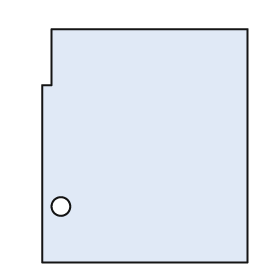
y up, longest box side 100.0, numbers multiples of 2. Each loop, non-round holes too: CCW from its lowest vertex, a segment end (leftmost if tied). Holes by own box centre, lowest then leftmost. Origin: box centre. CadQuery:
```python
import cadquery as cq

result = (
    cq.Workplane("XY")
    .moveTo(-44.0, -50.0)
    .lineTo(44.0, -50.0)
    .lineTo(44.0, 50.0)
    .lineTo(-40.0, 50.0)
    .lineTo(-40.0, 26.0)
    .lineTo(-44.0, 26.0)
    .close()
    .moveTo(-36.0, -26.0)
    .circle(4.0)
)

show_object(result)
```